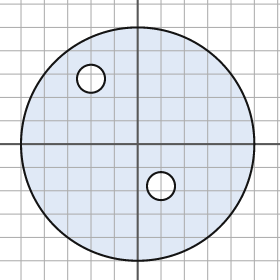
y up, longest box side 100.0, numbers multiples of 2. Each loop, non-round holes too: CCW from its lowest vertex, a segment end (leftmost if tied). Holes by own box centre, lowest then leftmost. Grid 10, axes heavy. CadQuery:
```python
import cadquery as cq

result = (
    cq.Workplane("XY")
    .moveTo(0.0, 0.0)
    .circle(50.0)
    .moveTo(10.0, -18.0)
    .circle(6.0)
    .moveTo(-20.0, 28.0)
    .circle(6.0)
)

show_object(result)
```